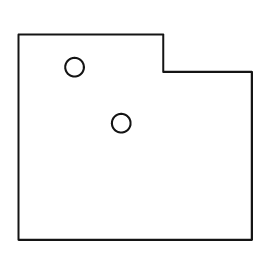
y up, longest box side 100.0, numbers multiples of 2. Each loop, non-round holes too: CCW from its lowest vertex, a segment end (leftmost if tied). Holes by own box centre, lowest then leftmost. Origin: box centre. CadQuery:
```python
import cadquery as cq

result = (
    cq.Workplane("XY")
    .moveTo(-50.0, -44.0)
    .lineTo(50.0, -44.0)
    .lineTo(50.0, 28.0)
    .lineTo(12.0, 28.0)
    .lineTo(12.0, 44.0)
    .lineTo(-50.0, 44.0)
    .close()
    .moveTo(-6.0, 6.0)
    .circle(4.0)
    .moveTo(-26.0, 30.0)
    .circle(4.0)
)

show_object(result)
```